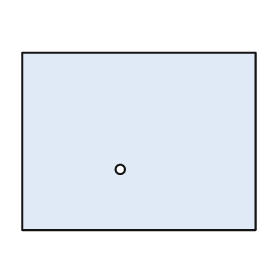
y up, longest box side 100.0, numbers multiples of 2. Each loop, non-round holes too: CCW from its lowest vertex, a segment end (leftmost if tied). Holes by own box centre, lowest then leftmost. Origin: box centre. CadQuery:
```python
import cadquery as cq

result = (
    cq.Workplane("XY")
    .moveTo(-50.0, -38.0)
    .lineTo(50.0, -38.0)
    .lineTo(50.0, 38.0)
    .lineTo(-50.0, 38.0)
    .close()
    .moveTo(-8.0, -12.0)
    .circle(2.0)
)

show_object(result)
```